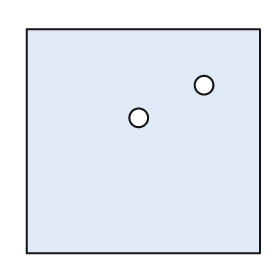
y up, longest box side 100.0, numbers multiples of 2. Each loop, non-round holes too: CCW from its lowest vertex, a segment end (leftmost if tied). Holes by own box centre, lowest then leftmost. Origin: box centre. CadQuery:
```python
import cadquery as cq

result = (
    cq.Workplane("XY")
    .moveTo(-50.0, -48.0)
    .lineTo(50.0, -48.0)
    .lineTo(50.0, 48.0)
    .lineTo(-50.0, 48.0)
    .close()
    .moveTo(-2.0, 10.0)
    .circle(4.0)
    .moveTo(26.0, 24.0)
    .circle(4.0)
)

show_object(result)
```